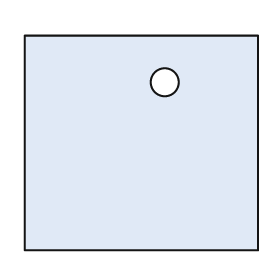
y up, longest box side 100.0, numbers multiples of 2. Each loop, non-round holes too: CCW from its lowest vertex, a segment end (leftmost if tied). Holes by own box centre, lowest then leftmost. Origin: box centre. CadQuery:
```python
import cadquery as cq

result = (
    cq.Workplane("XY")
    .moveTo(-50.0, -46.0)
    .lineTo(50.0, -46.0)
    .lineTo(50.0, 46.0)
    .lineTo(-50.0, 46.0)
    .close()
    .moveTo(10.0, 26.0)
    .circle(6.0)
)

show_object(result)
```